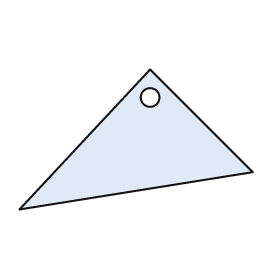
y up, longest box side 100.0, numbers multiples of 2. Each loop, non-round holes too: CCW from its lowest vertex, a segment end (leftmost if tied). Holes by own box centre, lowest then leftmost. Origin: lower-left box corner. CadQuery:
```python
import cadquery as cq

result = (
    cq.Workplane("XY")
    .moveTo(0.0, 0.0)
    .lineTo(100.0, 16.0)
    .lineTo(56.0, 60.0)
    .close()
    .moveTo(56.0, 48.0)
    .circle(4.0)
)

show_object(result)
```